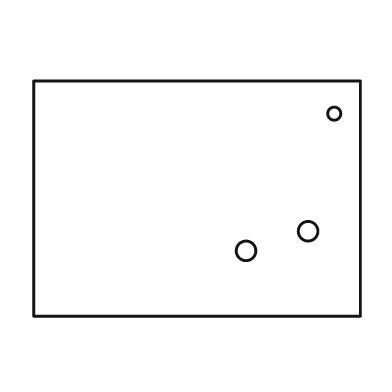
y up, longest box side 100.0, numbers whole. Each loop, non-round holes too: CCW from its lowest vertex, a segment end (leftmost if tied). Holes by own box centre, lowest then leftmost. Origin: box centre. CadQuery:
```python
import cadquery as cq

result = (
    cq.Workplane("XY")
    .moveTo(-50.0, -36.0)
    .lineTo(50.0, -36.0)
    .lineTo(50.0, 36.0)
    .lineTo(-50.0, 36.0)
    .close()
    .moveTo(15.0, -16.0)
    .circle(3.0)
    .moveTo(34.0, -10.0)
    .circle(3.0)
    .moveTo(42.0, 26.0)
    .circle(2.0)
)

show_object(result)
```